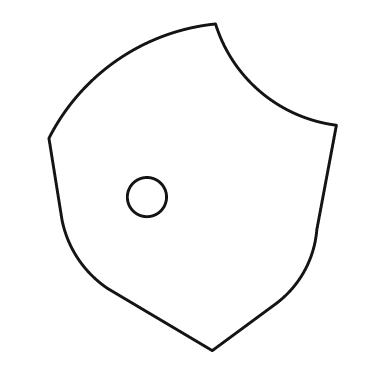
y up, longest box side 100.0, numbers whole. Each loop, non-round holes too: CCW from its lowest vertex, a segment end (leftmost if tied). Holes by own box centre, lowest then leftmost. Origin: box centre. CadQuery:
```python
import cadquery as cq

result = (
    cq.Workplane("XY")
    .moveTo(6.0, -50.0)
    .lineTo(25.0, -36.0)
    .threePointArc((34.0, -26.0), (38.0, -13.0))
    .lineTo(44.0, 19.0)
    .threePointArc((21.0, 29.0), (7.0, 50.0))
    .threePointArc((-23.0, 39.0), (-44.0, 15.0))
    .lineTo(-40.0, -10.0)
    .threePointArc((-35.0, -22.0), (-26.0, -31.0))
    .close()
    .moveTo(-14.0, -3.0)
    .circle(6.0)
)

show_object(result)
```